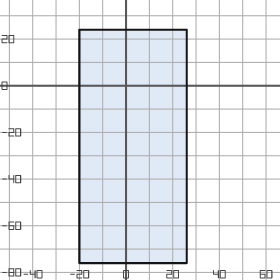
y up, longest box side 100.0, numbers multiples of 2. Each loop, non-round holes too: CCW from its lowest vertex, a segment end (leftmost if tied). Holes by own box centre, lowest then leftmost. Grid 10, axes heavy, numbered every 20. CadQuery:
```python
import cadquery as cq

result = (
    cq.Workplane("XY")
    .moveTo(-20.0, -76.0)
    .lineTo(26.0, -76.0)
    .lineTo(26.0, 24.0)
    .lineTo(-20.0, 24.0)
    .close()
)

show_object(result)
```